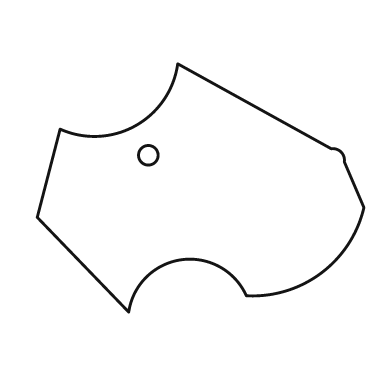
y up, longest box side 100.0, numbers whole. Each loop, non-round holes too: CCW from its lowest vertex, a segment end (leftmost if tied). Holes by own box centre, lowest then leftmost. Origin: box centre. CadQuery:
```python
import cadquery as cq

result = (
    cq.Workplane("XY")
    .moveTo(-22.0, -38.0)
    .threePointArc((-6.0, -22.0), (14.0, -33.0))
    .threePointArc((37.0, -26.0), (50.0, -6.0))
    .lineTo(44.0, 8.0)
    .threePointArc((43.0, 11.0), (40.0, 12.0))
    .lineTo(-7.0, 38.0)
    .threePointArc((-20.0, 19.0), (-43.0, 18.0))
    .lineTo(-50.0, -9.0)
    .close()
    .moveTo(-16.0, 10.0)
    .circle(3.0)
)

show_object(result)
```